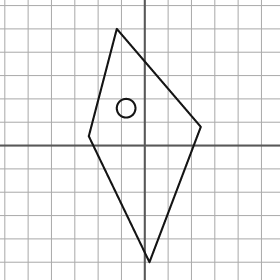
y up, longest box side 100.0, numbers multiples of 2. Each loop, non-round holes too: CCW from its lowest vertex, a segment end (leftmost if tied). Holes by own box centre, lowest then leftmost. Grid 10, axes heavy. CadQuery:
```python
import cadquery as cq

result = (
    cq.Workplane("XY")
    .moveTo(2.0, -50.0)
    .lineTo(24.0, 8.0)
    .lineTo(-12.0, 50.0)
    .lineTo(-24.0, 4.0)
    .close()
    .moveTo(-8.0, 16.0)
    .circle(4.0)
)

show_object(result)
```